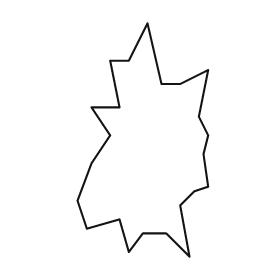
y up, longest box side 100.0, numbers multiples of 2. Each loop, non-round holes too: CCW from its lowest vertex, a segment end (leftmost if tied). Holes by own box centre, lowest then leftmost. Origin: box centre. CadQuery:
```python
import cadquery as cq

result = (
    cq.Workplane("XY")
    .moveTo(20.0, -50.0)
    .lineTo(16.0, -28.0)
    .lineTo(22.0, -22.0)
    .lineTo(28.0, -20.0)
    .lineTo(26.0, -6.0)
    .lineTo(28.0, 2.0)
    .lineTo(24.0, 10.0)
    .lineTo(28.0, 30.0)
    .lineTo(16.0, 24.0)
    .lineTo(8.0, 24.0)
    .lineTo(2.0, 50.0)
    .lineTo(-6.0, 34.0)
    .lineTo(-14.0, 34.0)
    .lineTo(-10.0, 14.0)
    .lineTo(-22.0, 14.0)
    .lineTo(-14.0, 2.0)
    .lineTo(-22.0, -10.0)
    .lineTo(-28.0, -26.0)
    .lineTo(-24.0, -38.0)
    .lineTo(-10.0, -34.0)
    .lineTo(-6.0, -48.0)
    .lineTo(0.0, -40.0)
    .lineTo(10.0, -40.0)
    .close()
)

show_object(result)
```